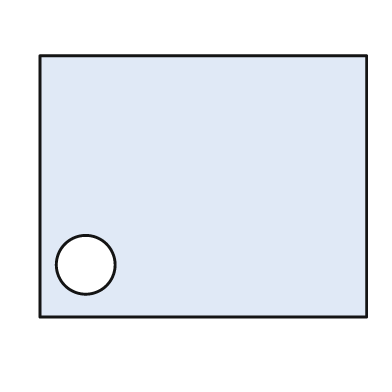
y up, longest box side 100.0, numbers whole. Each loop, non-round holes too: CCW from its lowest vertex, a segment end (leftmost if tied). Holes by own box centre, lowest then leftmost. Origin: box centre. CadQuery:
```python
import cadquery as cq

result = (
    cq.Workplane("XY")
    .moveTo(-50.0, -40.0)
    .lineTo(50.0, -40.0)
    .lineTo(50.0, 40.0)
    .lineTo(-50.0, 40.0)
    .close()
    .moveTo(-36.0, -24.0)
    .circle(9.0)
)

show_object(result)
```